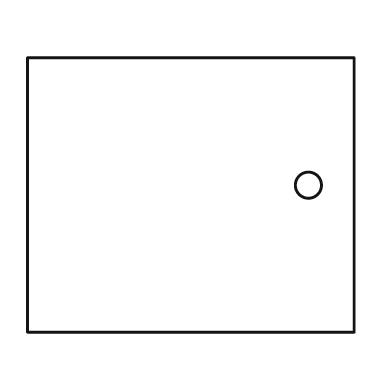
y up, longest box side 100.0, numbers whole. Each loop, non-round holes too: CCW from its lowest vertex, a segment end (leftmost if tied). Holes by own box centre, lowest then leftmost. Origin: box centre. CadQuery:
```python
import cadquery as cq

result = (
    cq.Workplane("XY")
    .moveTo(-50.0, -42.0)
    .lineTo(50.0, -42.0)
    .lineTo(50.0, 42.0)
    .lineTo(-50.0, 42.0)
    .close()
    .moveTo(36.0, 3.0)
    .circle(4.0)
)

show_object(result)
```